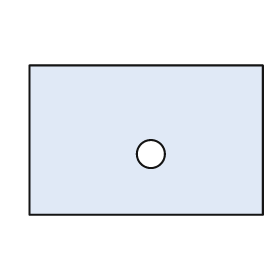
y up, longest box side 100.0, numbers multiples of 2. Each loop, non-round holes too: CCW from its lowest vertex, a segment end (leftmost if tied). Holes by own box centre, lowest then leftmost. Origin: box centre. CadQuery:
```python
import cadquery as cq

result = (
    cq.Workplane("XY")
    .moveTo(-50.0, -32.0)
    .lineTo(50.0, -32.0)
    .lineTo(50.0, 32.0)
    .lineTo(-50.0, 32.0)
    .close()
    .moveTo(2.0, -6.0)
    .circle(6.0)
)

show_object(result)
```